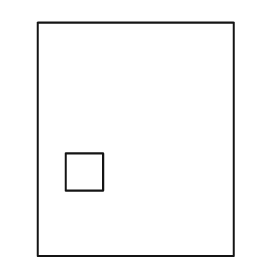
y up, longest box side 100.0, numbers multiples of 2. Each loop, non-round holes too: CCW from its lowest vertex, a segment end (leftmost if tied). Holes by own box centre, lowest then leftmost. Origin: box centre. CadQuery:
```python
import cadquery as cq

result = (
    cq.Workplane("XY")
    .moveTo(-42.0, -50.0)
    .lineTo(42.0, -50.0)
    .lineTo(42.0, 50.0)
    .lineTo(-42.0, 50.0)
    .close()
    .moveTo(-30.0, -22.0)
    .lineTo(-14.0, -22.0)
    .lineTo(-14.0, -6.0)
    .lineTo(-30.0, -6.0)
    .close()
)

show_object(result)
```